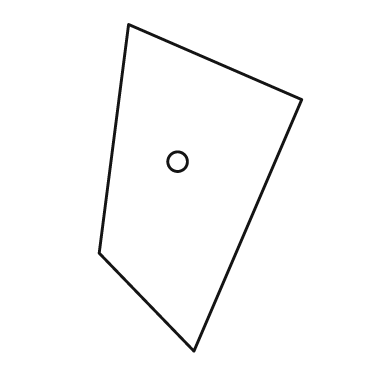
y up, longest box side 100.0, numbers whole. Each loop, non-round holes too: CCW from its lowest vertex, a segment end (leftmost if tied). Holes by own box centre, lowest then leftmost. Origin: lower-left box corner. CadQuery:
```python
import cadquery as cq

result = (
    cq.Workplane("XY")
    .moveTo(29.0, 0.0)
    .lineTo(62.0, 77.0)
    .lineTo(9.0, 100.0)
    .lineTo(0.0, 30.0)
    .close()
    .moveTo(24.0, 58.0)
    .circle(3.0)
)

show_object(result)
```